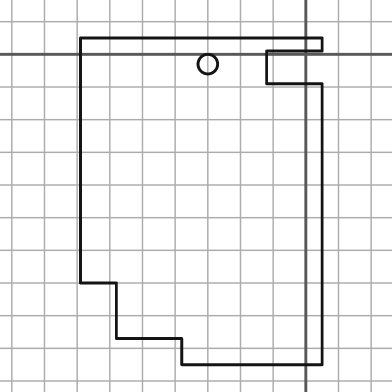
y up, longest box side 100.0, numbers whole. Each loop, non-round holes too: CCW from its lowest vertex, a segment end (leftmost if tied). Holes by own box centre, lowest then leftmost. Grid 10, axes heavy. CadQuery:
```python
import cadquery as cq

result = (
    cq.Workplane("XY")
    .moveTo(-38.0, -95.0)
    .lineTo(5.0, -95.0)
    .lineTo(5.0, -9.0)
    .lineTo(-12.0, -9.0)
    .lineTo(-12.0, 1.0)
    .lineTo(5.0, 1.0)
    .lineTo(5.0, 5.0)
    .lineTo(-69.0, 5.0)
    .lineTo(-69.0, -70.0)
    .lineTo(-58.0, -70.0)
    .lineTo(-58.0, -87.0)
    .lineTo(-38.0, -87.0)
    .close()
    .moveTo(-30.0, -3.0)
    .circle(3.0)
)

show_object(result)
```